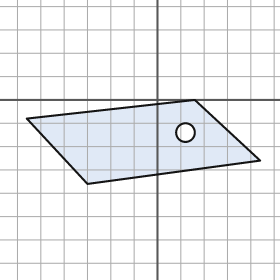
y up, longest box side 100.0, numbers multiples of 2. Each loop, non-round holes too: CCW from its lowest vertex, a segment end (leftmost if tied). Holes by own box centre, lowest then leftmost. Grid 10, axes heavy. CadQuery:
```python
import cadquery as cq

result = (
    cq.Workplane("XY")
    .moveTo(-30.0, -36.0)
    .lineTo(44.0, -26.0)
    .lineTo(16.0, 0.0)
    .lineTo(-56.0, -8.0)
    .close()
    .moveTo(12.0, -14.0)
    .circle(4.0)
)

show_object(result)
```